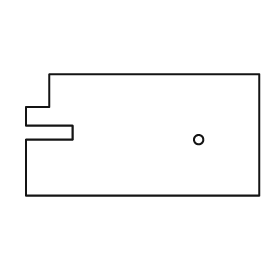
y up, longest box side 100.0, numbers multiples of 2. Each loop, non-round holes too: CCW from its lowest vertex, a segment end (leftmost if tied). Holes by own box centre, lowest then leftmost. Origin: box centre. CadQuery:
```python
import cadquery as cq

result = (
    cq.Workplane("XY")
    .moveTo(-50.0, -26.0)
    .lineTo(50.0, -26.0)
    .lineTo(50.0, 26.0)
    .lineTo(-40.0, 26.0)
    .lineTo(-40.0, 12.0)
    .lineTo(-50.0, 12.0)
    .lineTo(-50.0, 4.0)
    .lineTo(-30.0, 4.0)
    .lineTo(-30.0, -2.0)
    .lineTo(-50.0, -2.0)
    .close()
    .moveTo(24.0, -2.0)
    .circle(2.0)
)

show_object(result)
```